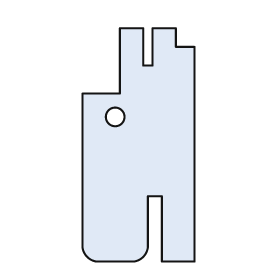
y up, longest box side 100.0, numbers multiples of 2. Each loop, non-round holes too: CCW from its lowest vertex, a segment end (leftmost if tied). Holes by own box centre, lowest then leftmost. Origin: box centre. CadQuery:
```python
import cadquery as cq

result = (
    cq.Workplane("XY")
    .moveTo(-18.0, -50.0)
    .lineTo(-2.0, -50.0)
    .threePointArc((2.0, -48.0), (4.0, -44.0))
    .lineTo(4.0, -22.0)
    .lineTo(10.0, -22.0)
    .lineTo(10.0, -50.0)
    .lineTo(24.0, -50.0)
    .lineTo(24.0, 42.0)
    .lineTo(16.0, 42.0)
    .lineTo(16.0, 50.0)
    .lineTo(6.0, 50.0)
    .lineTo(6.0, 34.0)
    .lineTo(2.0, 34.0)
    .lineTo(2.0, 50.0)
    .lineTo(-8.0, 50.0)
    .lineTo(-8.0, 22.0)
    .lineTo(-24.0, 22.0)
    .lineTo(-24.0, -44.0)
    .threePointArc((-22.0, -48.0), (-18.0, -50.0))
    .close()
    .moveTo(-10.0, 12.0)
    .circle(4.0)
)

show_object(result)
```